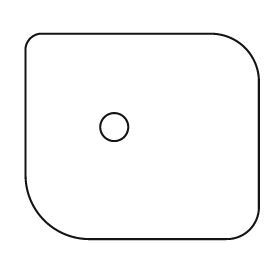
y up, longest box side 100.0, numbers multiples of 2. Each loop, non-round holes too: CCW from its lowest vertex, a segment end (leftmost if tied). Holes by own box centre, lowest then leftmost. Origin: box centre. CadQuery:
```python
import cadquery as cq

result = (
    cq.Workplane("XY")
    .moveTo(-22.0, -44.0)
    .lineTo(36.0, -44.0)
    .threePointArc((46.0, -40.0), (50.0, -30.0))
    .lineTo(50.0, 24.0)
    .threePointArc((44.0, 38.0), (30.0, 44.0))
    .lineTo(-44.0, 44.0)
    .threePointArc((-48.0, 42.0), (-50.0, 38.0))
    .lineTo(-50.0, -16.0)
    .threePointArc((-42.0, -36.0), (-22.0, -44.0))
    .close()
    .moveTo(-12.0, 4.0)
    .circle(6.0)
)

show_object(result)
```